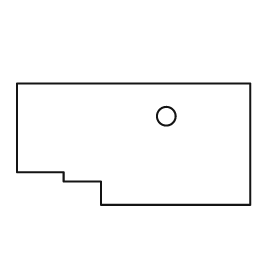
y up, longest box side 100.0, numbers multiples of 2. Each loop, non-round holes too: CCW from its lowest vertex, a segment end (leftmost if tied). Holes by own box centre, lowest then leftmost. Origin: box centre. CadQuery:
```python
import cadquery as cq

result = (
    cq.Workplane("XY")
    .moveTo(-14.0, -26.0)
    .lineTo(50.0, -26.0)
    .lineTo(50.0, 26.0)
    .lineTo(-50.0, 26.0)
    .lineTo(-50.0, -12.0)
    .lineTo(-30.0, -12.0)
    .lineTo(-30.0, -16.0)
    .lineTo(-14.0, -16.0)
    .close()
    .moveTo(14.0, 12.0)
    .circle(4.0)
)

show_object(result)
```